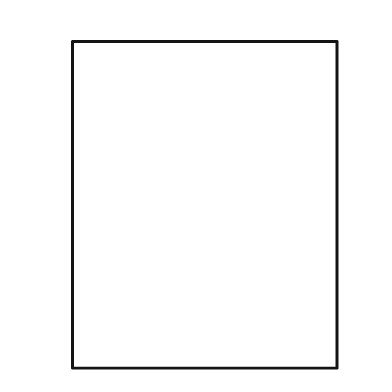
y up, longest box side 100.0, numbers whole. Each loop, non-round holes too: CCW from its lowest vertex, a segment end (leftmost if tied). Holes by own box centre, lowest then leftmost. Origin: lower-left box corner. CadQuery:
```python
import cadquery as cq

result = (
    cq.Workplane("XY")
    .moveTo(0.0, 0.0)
    .lineTo(81.0, 0.0)
    .lineTo(81.0, 100.0)
    .lineTo(0.0, 100.0)
    .close()
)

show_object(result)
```